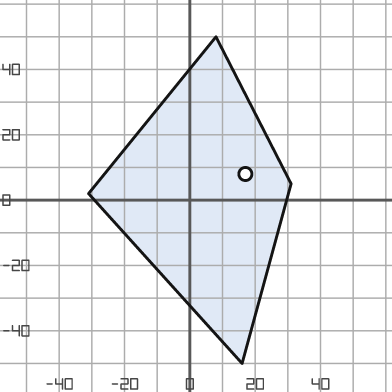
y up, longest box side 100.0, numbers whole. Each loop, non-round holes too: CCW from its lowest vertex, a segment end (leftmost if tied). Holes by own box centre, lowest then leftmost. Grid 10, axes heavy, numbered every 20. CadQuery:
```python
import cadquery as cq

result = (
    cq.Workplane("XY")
    .moveTo(16.0, -50.0)
    .lineTo(31.0, 5.0)
    .lineTo(8.0, 50.0)
    .lineTo(-31.0, 2.0)
    .close()
    .moveTo(17.0, 8.0)
    .circle(2.0)
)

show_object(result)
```